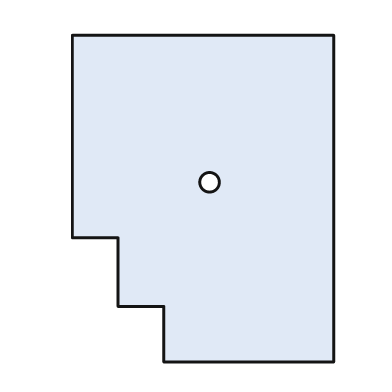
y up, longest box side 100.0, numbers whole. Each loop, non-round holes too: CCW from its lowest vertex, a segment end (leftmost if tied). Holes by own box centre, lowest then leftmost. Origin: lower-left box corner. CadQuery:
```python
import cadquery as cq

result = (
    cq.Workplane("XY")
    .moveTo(28.0, 0.0)
    .lineTo(80.0, 0.0)
    .lineTo(80.0, 100.0)
    .lineTo(0.0, 100.0)
    .lineTo(0.0, 38.0)
    .lineTo(14.0, 38.0)
    .lineTo(14.0, 17.0)
    .lineTo(28.0, 17.0)
    .close()
    .moveTo(42.0, 55.0)
    .circle(3.0)
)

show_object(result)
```